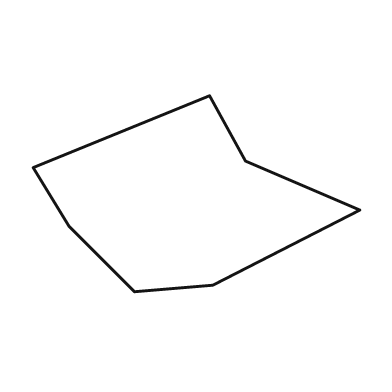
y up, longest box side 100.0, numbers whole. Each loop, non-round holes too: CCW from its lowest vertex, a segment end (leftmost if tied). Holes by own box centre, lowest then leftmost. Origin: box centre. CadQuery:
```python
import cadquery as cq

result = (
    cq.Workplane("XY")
    .moveTo(-19.0, -30.0)
    .lineTo(5.0, -28.0)
    .lineTo(50.0, -5.0)
    .lineTo(15.0, 10.0)
    .lineTo(4.0, 30.0)
    .lineTo(-50.0, 8.0)
    .lineTo(-39.0, -10.0)
    .close()
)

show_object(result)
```